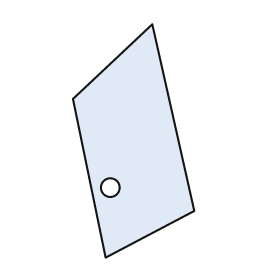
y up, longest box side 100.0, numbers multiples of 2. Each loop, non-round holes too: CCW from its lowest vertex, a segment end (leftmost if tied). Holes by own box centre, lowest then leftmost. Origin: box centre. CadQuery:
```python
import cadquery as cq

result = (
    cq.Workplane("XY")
    .moveTo(-12.0, -50.0)
    .lineTo(26.0, -30.0)
    .lineTo(8.0, 50.0)
    .lineTo(-26.0, 18.0)
    .close()
    .moveTo(-10.0, -20.0)
    .circle(4.0)
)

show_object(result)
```